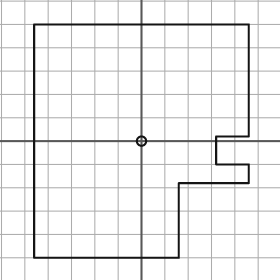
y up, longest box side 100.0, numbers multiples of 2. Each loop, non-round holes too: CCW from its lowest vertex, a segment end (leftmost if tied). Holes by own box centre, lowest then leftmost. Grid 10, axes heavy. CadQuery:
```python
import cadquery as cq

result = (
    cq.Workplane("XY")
    .moveTo(-46.0, -50.0)
    .lineTo(16.0, -50.0)
    .lineTo(16.0, -18.0)
    .lineTo(46.0, -18.0)
    .lineTo(46.0, -10.0)
    .lineTo(32.0, -10.0)
    .lineTo(32.0, 2.0)
    .lineTo(46.0, 2.0)
    .lineTo(46.0, 50.0)
    .lineTo(-46.0, 50.0)
    .close()
    .moveTo(0.0, 0.0)
    .circle(2.0)
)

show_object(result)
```